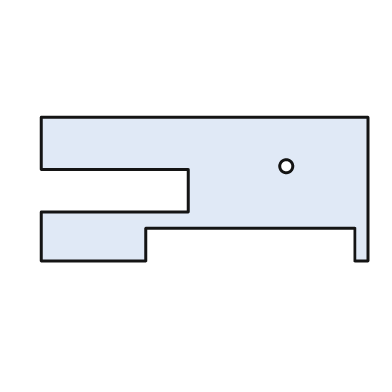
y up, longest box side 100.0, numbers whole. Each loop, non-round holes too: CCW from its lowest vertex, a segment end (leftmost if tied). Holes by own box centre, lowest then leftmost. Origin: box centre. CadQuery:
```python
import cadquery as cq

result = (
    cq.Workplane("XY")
    .moveTo(-50.0, -22.0)
    .lineTo(-18.0, -22.0)
    .lineTo(-18.0, -12.0)
    .lineTo(46.0, -12.0)
    .lineTo(46.0, -22.0)
    .lineTo(50.0, -22.0)
    .lineTo(50.0, 22.0)
    .lineTo(-50.0, 22.0)
    .lineTo(-50.0, 6.0)
    .lineTo(-5.0, 6.0)
    .lineTo(-5.0, -7.0)
    .lineTo(-50.0, -7.0)
    .close()
    .moveTo(25.0, 7.0)
    .circle(2.0)
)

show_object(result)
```